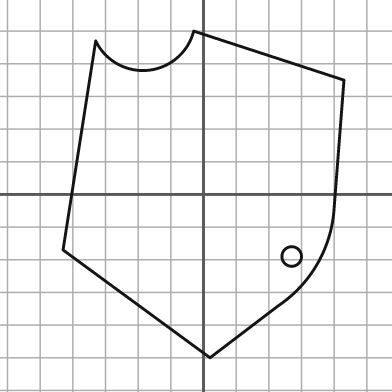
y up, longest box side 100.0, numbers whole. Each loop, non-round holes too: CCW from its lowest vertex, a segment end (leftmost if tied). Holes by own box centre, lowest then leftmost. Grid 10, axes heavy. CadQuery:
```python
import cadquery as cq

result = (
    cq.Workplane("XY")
    .moveTo(2.0, -50.0)
    .lineTo(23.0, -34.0)
    .threePointArc((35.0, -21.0), (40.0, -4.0))
    .lineTo(43.0, 35.0)
    .lineTo(-3.0, 50.0)
    .threePointArc((-17.0, 38.0), (-33.0, 47.0))
    .lineTo(-43.0, -17.0)
    .close()
    .moveTo(27.0, -19.0)
    .circle(3.0)
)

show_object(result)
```